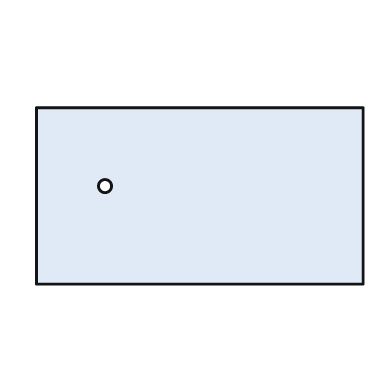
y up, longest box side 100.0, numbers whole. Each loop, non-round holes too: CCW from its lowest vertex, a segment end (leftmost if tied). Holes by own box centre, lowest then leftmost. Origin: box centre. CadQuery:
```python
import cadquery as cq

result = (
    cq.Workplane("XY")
    .moveTo(-50.0, -27.0)
    .lineTo(50.0, -27.0)
    .lineTo(50.0, 27.0)
    .lineTo(-50.0, 27.0)
    .close()
    .moveTo(-29.0, 3.0)
    .circle(2.0)
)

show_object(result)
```